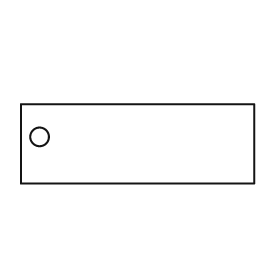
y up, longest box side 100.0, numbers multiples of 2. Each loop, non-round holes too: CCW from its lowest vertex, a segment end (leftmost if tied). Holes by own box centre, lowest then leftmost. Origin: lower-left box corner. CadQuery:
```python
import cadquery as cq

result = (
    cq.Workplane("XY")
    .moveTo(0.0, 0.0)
    .lineTo(100.0, 0.0)
    .lineTo(100.0, 34.0)
    .lineTo(0.0, 34.0)
    .close()
    .moveTo(8.0, 20.0)
    .circle(4.0)
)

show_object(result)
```